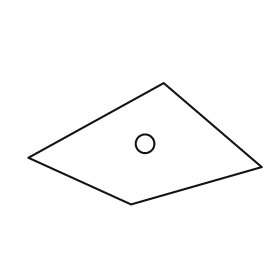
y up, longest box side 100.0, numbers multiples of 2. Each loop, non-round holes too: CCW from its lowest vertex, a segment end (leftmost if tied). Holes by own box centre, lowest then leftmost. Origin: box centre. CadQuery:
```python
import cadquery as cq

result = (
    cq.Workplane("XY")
    .moveTo(-6.0, -26.0)
    .lineTo(50.0, -10.0)
    .lineTo(8.0, 26.0)
    .lineTo(-50.0, -6.0)
    .close()
    .moveTo(0.0, 0.0)
    .circle(4.0)
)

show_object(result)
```